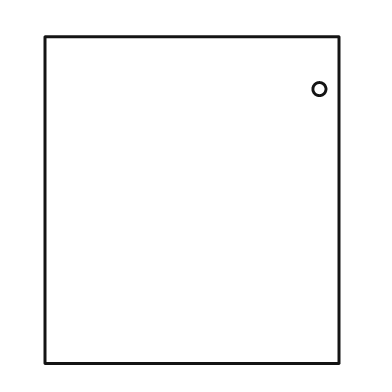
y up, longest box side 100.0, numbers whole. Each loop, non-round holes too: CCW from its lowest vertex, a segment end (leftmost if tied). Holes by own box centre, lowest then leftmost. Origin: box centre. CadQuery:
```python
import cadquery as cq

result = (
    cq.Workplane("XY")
    .moveTo(-45.0, -50.0)
    .lineTo(45.0, -50.0)
    .lineTo(45.0, 50.0)
    .lineTo(-45.0, 50.0)
    .close()
    .moveTo(39.0, 34.0)
    .circle(2.0)
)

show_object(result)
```